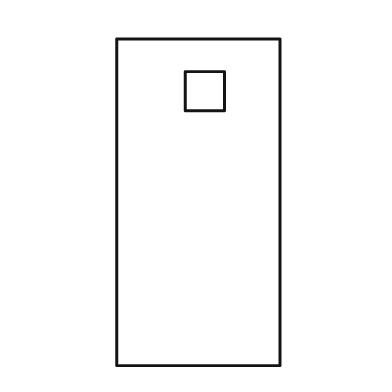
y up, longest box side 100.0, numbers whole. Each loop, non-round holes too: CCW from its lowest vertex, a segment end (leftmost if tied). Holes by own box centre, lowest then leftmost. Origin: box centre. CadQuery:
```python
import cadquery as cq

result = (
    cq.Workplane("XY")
    .moveTo(-25.0, -50.0)
    .lineTo(25.0, -50.0)
    .lineTo(25.0, 50.0)
    .lineTo(-25.0, 50.0)
    .close()
    .moveTo(-4.0, 28.0)
    .lineTo(8.0, 28.0)
    .lineTo(8.0, 40.0)
    .lineTo(-4.0, 40.0)
    .close()
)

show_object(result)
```